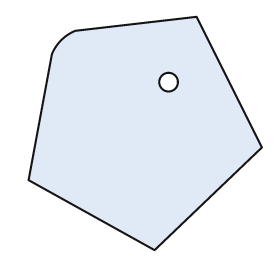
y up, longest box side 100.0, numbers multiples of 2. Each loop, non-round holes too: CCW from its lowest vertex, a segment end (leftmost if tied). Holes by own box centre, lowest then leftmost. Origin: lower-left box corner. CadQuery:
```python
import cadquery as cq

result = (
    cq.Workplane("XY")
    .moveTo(54.0, 0.0)
    .lineTo(100.0, 44.0)
    .lineTo(72.0, 100.0)
    .lineTo(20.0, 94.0)
    .threePointArc((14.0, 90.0), (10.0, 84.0))
    .lineTo(0.0, 30.0)
    .close()
    .moveTo(60.0, 72.0)
    .circle(4.0)
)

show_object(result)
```